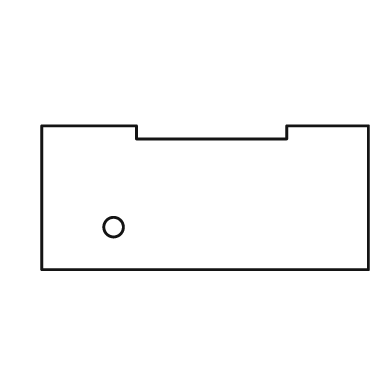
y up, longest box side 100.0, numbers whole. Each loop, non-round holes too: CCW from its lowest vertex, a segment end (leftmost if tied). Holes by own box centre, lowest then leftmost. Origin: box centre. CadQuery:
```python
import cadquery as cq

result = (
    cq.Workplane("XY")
    .moveTo(-50.0, -22.0)
    .lineTo(50.0, -22.0)
    .lineTo(50.0, 22.0)
    .lineTo(25.0, 22.0)
    .lineTo(25.0, 18.0)
    .lineTo(-21.0, 18.0)
    .lineTo(-21.0, 22.0)
    .lineTo(-50.0, 22.0)
    .close()
    .moveTo(-28.0, -9.0)
    .circle(3.0)
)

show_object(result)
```